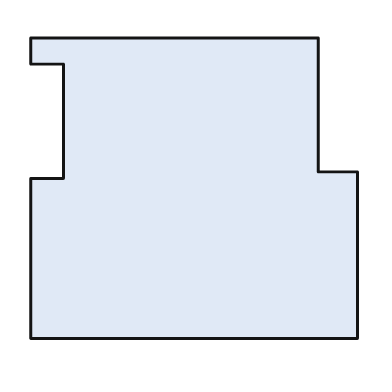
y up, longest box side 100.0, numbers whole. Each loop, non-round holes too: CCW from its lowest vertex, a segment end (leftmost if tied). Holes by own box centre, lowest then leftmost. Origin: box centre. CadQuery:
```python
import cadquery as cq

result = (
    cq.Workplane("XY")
    .moveTo(-50.0, -46.0)
    .lineTo(50.0, -46.0)
    .lineTo(50.0, 5.0)
    .lineTo(38.0, 5.0)
    .lineTo(38.0, 46.0)
    .lineTo(-50.0, 46.0)
    .lineTo(-50.0, 38.0)
    .lineTo(-40.0, 38.0)
    .lineTo(-40.0, 3.0)
    .lineTo(-50.0, 3.0)
    .close()
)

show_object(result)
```